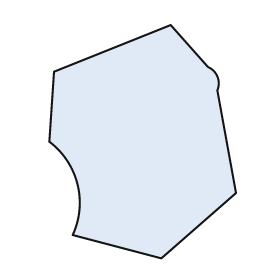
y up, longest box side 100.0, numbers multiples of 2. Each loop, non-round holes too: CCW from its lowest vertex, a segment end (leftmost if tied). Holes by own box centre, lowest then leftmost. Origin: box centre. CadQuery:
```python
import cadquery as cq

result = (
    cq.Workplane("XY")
    .moveTo(8.0, -50.0)
    .lineTo(40.0, -22.0)
    .lineTo(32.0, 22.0)
    .threePointArc((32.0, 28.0), (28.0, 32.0))
    .lineTo(12.0, 50.0)
    .lineTo(-38.0, 30.0)
    .lineTo(-40.0, 0.0)
    .threePointArc((-28.0, -18.0), (-30.0, -40.0))
    .close()
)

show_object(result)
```